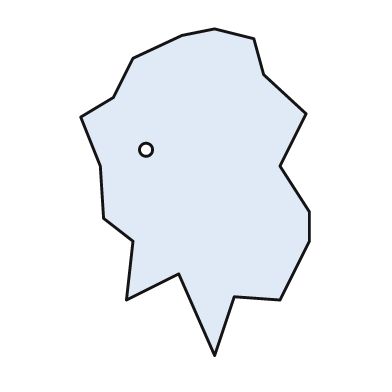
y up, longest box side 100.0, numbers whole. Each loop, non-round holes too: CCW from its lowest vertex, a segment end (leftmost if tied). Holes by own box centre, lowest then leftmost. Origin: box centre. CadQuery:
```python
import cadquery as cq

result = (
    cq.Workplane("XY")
    .moveTo(6.0, -50.0)
    .lineTo(12.0, -32.0)
    .lineTo(26.0, -33.0)
    .lineTo(35.0, -15.0)
    .lineTo(35.0, -6.0)
    .lineTo(26.0, 8.0)
    .lineTo(34.0, 24.0)
    .lineTo(21.0, 36.0)
    .lineTo(18.0, 47.0)
    .lineTo(6.0, 50.0)
    .lineTo(-4.0, 48.0)
    .lineTo(-19.0, 41.0)
    .lineTo(-25.0, 29.0)
    .lineTo(-35.0, 23.0)
    .lineTo(-29.0, 8.0)
    .lineTo(-28.0, -8.0)
    .lineTo(-19.0, -15.0)
    .lineTo(-21.0, -33.0)
    .lineTo(-5.0, -25.0)
    .close()
    .moveTo(-15.0, 13.0)
    .circle(2.0)
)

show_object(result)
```